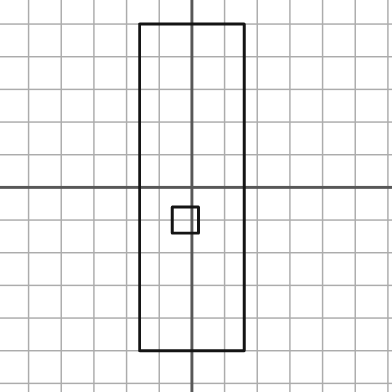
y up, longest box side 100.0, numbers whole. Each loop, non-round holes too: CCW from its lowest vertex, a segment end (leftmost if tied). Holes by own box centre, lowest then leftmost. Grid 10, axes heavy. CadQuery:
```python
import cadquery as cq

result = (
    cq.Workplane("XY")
    .moveTo(-16.0, -50.0)
    .lineTo(16.0, -50.0)
    .lineTo(16.0, 50.0)
    .lineTo(-16.0, 50.0)
    .close()
    .moveTo(-6.0, -14.0)
    .lineTo(2.0, -14.0)
    .lineTo(2.0, -6.0)
    .lineTo(-6.0, -6.0)
    .close()
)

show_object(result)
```